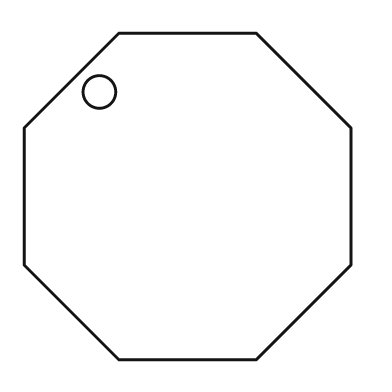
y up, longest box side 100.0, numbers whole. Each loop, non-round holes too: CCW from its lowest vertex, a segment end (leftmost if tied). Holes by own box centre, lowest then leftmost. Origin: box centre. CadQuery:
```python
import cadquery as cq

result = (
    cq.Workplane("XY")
    .moveTo(-21.0, -50.0)
    .lineTo(21.0, -50.0)
    .lineTo(50.0, -21.0)
    .lineTo(50.0, 21.0)
    .lineTo(21.0, 50.0)
    .lineTo(-21.0, 50.0)
    .lineTo(-50.0, 21.0)
    .lineTo(-50.0, -21.0)
    .close()
    .moveTo(-27.0, 32.0)
    .circle(5.0)
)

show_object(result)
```